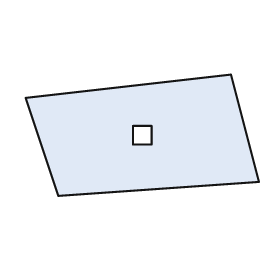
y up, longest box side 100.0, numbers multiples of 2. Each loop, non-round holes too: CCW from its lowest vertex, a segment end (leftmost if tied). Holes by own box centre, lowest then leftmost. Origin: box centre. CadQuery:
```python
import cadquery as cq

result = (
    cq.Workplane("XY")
    .moveTo(-36.0, -26.0)
    .lineTo(50.0, -20.0)
    .lineTo(38.0, 26.0)
    .lineTo(-50.0, 16.0)
    .close()
    .moveTo(-4.0, -4.0)
    .lineTo(4.0, -4.0)
    .lineTo(4.0, 4.0)
    .lineTo(-4.0, 4.0)
    .close()
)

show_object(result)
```